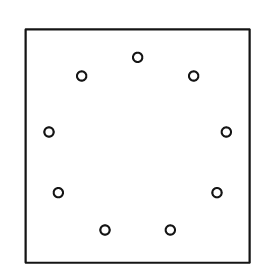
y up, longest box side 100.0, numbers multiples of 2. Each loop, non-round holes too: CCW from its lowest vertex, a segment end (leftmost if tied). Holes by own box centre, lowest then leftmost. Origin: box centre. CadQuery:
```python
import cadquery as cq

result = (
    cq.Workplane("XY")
    .moveTo(-48.0, -50.0)
    .lineTo(48.0, -50.0)
    .lineTo(48.0, 50.0)
    .lineTo(-48.0, 50.0)
    .close()
    .moveTo(-14.0, -36.0)
    .circle(2.0)
    .moveTo(14.0, -36.0)
    .circle(2.0)
    .moveTo(-34.0, -20.0)
    .circle(2.0)
    .moveTo(34.0, -20.0)
    .circle(2.0)
    .moveTo(-38.0, 6.0)
    .circle(2.0)
    .moveTo(38.0, 6.0)
    .circle(2.0)
    .moveTo(-24.0, 30.0)
    .circle(2.0)
    .moveTo(24.0, 30.0)
    .circle(2.0)
    .moveTo(0.0, 38.0)
    .circle(2.0)
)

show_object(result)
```